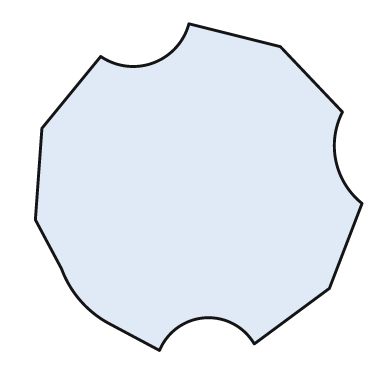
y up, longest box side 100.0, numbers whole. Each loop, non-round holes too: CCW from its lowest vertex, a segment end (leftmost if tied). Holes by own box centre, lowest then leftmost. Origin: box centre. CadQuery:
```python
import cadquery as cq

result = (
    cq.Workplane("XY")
    .moveTo(-12.0, -50.0)
    .threePointArc((2.0, -40.0), (17.0, -48.0))
    .lineTo(40.0, -31.0)
    .lineTo(50.0, -5.0)
    .threePointArc((42.0, 8.0), (44.0, 23.0))
    .lineTo(25.0, 43.0)
    .lineTo(-3.0, 50.0)
    .threePointArc((-14.0, 38.0), (-30.0, 40.0))
    .lineTo(-48.0, 18.0)
    .lineTo(-50.0, -10.0)
    .lineTo(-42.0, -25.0)
    .threePointArc((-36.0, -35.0), (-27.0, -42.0))
    .close()
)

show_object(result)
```